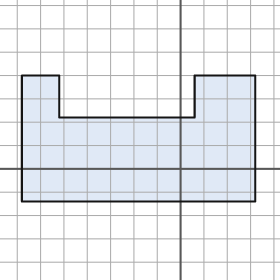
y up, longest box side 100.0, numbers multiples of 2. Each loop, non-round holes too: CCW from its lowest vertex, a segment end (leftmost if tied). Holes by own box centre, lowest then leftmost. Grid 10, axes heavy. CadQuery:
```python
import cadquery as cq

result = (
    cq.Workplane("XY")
    .moveTo(-68.0, -14.0)
    .lineTo(32.0, -14.0)
    .lineTo(32.0, 40.0)
    .lineTo(6.0, 40.0)
    .lineTo(6.0, 22.0)
    .lineTo(-52.0, 22.0)
    .lineTo(-52.0, 40.0)
    .lineTo(-68.0, 40.0)
    .close()
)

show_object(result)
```